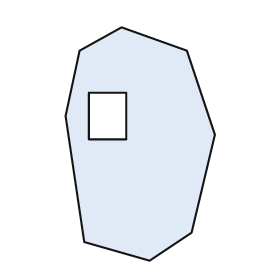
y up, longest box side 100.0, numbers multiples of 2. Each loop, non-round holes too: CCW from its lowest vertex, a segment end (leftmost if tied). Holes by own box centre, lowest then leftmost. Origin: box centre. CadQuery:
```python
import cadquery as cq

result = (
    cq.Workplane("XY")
    .moveTo(4.0, -50.0)
    .lineTo(22.0, -38.0)
    .lineTo(32.0, 4.0)
    .lineTo(20.0, 40.0)
    .lineTo(-8.0, 50.0)
    .lineTo(-26.0, 40.0)
    .lineTo(-32.0, 12.0)
    .lineTo(-24.0, -42.0)
    .close()
    .moveTo(-22.0, 2.0)
    .lineTo(-6.0, 2.0)
    .lineTo(-6.0, 22.0)
    .lineTo(-22.0, 22.0)
    .close()
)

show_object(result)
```